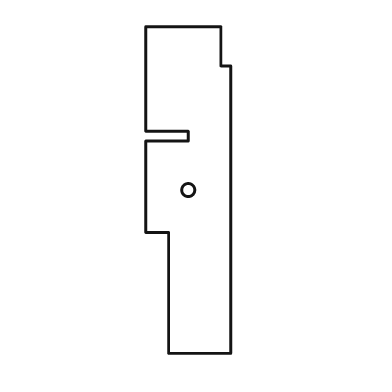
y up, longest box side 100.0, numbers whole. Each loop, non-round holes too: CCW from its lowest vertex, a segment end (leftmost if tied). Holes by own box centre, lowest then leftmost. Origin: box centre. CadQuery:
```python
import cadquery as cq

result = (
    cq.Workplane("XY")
    .moveTo(-6.0, -50.0)
    .lineTo(13.0, -50.0)
    .lineTo(13.0, 38.0)
    .lineTo(10.0, 38.0)
    .lineTo(10.0, 50.0)
    .lineTo(-13.0, 50.0)
    .lineTo(-13.0, 18.0)
    .lineTo(0.0, 18.0)
    .lineTo(0.0, 15.0)
    .lineTo(-13.0, 15.0)
    .lineTo(-13.0, -13.0)
    .lineTo(-6.0, -13.0)
    .close()
    .moveTo(0.0, 0.0)
    .circle(2.0)
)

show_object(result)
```